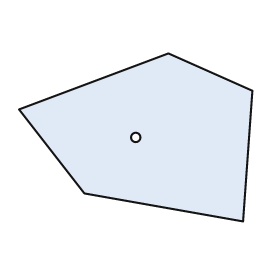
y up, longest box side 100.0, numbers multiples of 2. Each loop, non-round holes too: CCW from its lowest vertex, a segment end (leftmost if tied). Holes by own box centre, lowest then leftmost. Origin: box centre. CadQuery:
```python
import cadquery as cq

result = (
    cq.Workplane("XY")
    .moveTo(46.0, -36.0)
    .lineTo(50.0, 20.0)
    .lineTo(14.0, 36.0)
    .lineTo(-50.0, 12.0)
    .lineTo(-22.0, -24.0)
    .close()
    .moveTo(0.0, 0.0)
    .circle(2.0)
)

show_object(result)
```